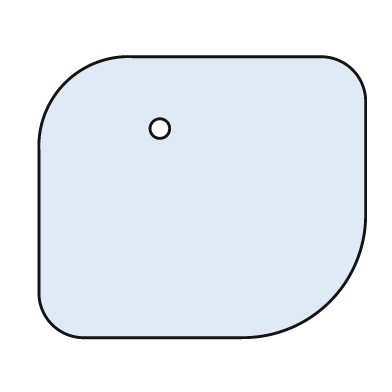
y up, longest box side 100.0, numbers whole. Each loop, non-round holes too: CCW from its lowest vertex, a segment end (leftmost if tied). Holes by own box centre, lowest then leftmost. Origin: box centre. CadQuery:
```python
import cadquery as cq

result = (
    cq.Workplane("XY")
    .moveTo(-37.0, -43.0)
    .lineTo(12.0, -43.0)
    .threePointArc((39.0, -32.0), (50.0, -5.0))
    .lineTo(50.0, 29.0)
    .threePointArc((46.0, 39.0), (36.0, 43.0))
    .lineTo(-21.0, 43.0)
    .threePointArc((-42.0, 35.0), (-50.0, 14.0))
    .lineTo(-50.0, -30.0)
    .threePointArc((-46.0, -39.0), (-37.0, -43.0))
    .close()
    .moveTo(-13.0, 21.0)
    .circle(3.0)
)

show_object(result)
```